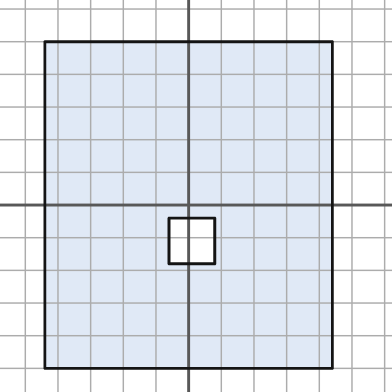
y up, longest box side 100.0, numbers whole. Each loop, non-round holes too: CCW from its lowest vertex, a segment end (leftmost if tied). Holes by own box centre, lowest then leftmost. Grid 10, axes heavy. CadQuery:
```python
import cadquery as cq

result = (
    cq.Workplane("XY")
    .moveTo(-44.0, -50.0)
    .lineTo(44.0, -50.0)
    .lineTo(44.0, 50.0)
    .lineTo(-44.0, 50.0)
    .close()
    .moveTo(-6.0, -18.0)
    .lineTo(8.0, -18.0)
    .lineTo(8.0, -4.0)
    .lineTo(-6.0, -4.0)
    .close()
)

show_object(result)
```